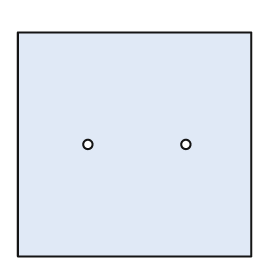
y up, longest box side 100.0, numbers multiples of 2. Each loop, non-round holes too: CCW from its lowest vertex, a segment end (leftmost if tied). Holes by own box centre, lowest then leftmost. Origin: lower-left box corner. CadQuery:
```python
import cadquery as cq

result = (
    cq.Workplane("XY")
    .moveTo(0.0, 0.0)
    .lineTo(100.0, 0.0)
    .lineTo(100.0, 96.0)
    .lineTo(0.0, 96.0)
    .close()
    .moveTo(30.0, 48.0)
    .circle(2.0)
    .moveTo(72.0, 48.0)
    .circle(2.0)
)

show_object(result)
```